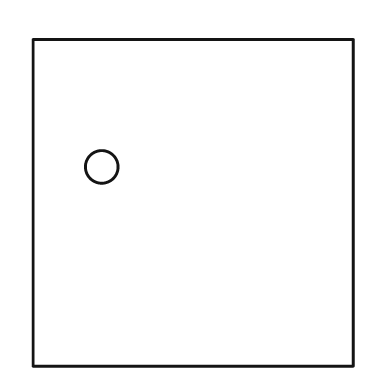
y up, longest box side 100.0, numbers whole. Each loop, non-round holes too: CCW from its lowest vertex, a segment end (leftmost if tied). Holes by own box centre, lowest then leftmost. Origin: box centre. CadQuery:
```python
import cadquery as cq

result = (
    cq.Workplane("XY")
    .moveTo(-49.0, -50.0)
    .lineTo(49.0, -50.0)
    .lineTo(49.0, 50.0)
    .lineTo(-49.0, 50.0)
    .close()
    .moveTo(-28.0, 11.0)
    .circle(5.0)
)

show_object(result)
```